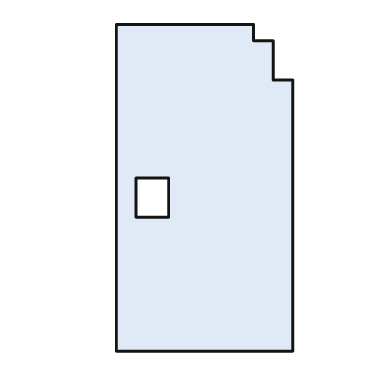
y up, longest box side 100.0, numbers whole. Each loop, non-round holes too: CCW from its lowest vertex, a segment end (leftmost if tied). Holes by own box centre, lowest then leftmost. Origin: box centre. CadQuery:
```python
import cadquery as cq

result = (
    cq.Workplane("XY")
    .moveTo(-27.0, -50.0)
    .lineTo(27.0, -50.0)
    .lineTo(27.0, 33.0)
    .lineTo(21.0, 33.0)
    .lineTo(21.0, 45.0)
    .lineTo(15.0, 45.0)
    .lineTo(15.0, 50.0)
    .lineTo(-27.0, 50.0)
    .close()
    .moveTo(-21.0, -9.0)
    .lineTo(-11.0, -9.0)
    .lineTo(-11.0, 3.0)
    .lineTo(-21.0, 3.0)
    .close()
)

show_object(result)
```